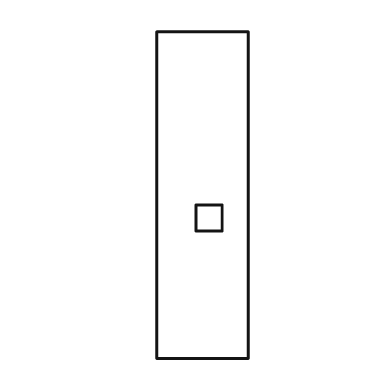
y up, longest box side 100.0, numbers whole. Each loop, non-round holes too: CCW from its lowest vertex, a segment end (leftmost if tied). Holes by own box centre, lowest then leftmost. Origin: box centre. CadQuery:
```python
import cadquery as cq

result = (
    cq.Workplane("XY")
    .moveTo(-14.0, -50.0)
    .lineTo(14.0, -50.0)
    .lineTo(14.0, 50.0)
    .lineTo(-14.0, 50.0)
    .close()
    .moveTo(-2.0, -11.0)
    .lineTo(6.0, -11.0)
    .lineTo(6.0, -3.0)
    .lineTo(-2.0, -3.0)
    .close()
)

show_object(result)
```